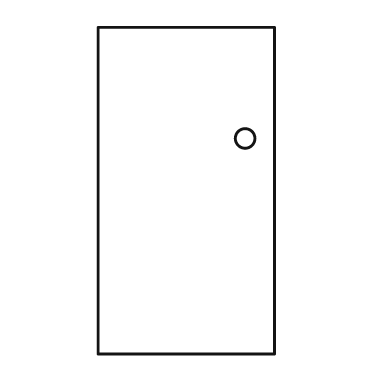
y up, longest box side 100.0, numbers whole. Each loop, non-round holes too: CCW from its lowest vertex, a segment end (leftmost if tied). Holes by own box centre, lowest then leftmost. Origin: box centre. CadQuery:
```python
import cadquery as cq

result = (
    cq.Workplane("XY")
    .moveTo(-27.0, -50.0)
    .lineTo(27.0, -50.0)
    .lineTo(27.0, 50.0)
    .lineTo(-27.0, 50.0)
    .close()
    .moveTo(18.0, 16.0)
    .circle(3.0)
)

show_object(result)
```